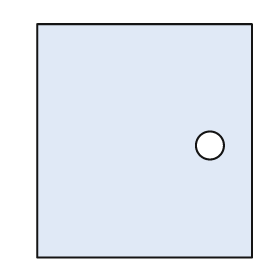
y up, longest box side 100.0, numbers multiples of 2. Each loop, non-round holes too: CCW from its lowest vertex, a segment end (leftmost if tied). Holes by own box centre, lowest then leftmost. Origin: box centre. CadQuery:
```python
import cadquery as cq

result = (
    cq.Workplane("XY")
    .moveTo(-46.0, -50.0)
    .lineTo(46.0, -50.0)
    .lineTo(46.0, 50.0)
    .lineTo(-46.0, 50.0)
    .close()
    .moveTo(28.0, -2.0)
    .circle(6.0)
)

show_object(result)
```